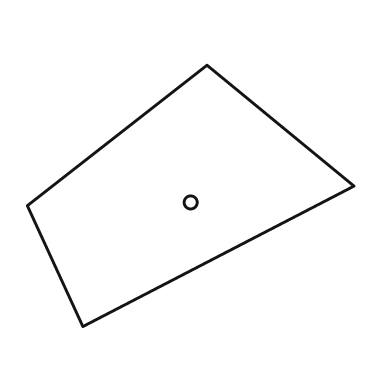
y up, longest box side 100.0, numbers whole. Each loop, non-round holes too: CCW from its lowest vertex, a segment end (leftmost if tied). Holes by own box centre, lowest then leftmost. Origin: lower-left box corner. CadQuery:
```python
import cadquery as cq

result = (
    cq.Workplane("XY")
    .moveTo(17.0, 0.0)
    .lineTo(100.0, 43.0)
    .lineTo(55.0, 80.0)
    .lineTo(0.0, 37.0)
    .close()
    .moveTo(50.0, 38.0)
    .circle(2.0)
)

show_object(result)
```